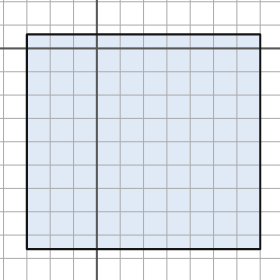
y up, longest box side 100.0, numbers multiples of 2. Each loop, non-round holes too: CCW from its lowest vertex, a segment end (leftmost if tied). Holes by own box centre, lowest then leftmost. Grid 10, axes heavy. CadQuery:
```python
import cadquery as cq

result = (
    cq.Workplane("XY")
    .moveTo(-30.0, -86.0)
    .lineTo(70.0, -86.0)
    .lineTo(70.0, 6.0)
    .lineTo(-30.0, 6.0)
    .close()
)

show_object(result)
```